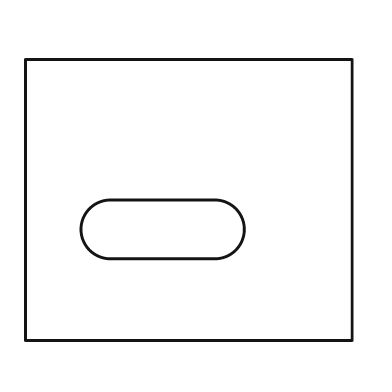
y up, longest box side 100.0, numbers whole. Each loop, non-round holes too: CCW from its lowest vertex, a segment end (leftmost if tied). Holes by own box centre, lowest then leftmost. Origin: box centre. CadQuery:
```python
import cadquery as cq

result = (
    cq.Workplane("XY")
    .moveTo(-50.0, -43.0)
    .lineTo(50.0, -43.0)
    .lineTo(50.0, 43.0)
    .lineTo(-50.0, 43.0)
    .close()
    .moveTo(-24.0, -18.0)
    .lineTo(8.0, -18.0)
    .threePointArc((17.0, -9.0), (8.0, 0.0))
    .lineTo(-24.0, 0.0)
    .threePointArc((-33.0, -9.0), (-24.0, -18.0))
    .close()
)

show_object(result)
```